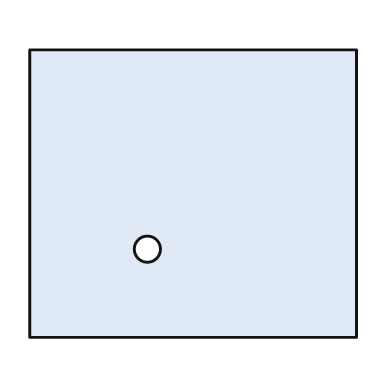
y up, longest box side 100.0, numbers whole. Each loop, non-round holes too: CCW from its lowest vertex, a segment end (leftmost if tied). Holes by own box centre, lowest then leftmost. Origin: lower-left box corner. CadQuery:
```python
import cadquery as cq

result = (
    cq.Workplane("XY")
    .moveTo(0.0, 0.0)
    .lineTo(100.0, 0.0)
    .lineTo(100.0, 88.0)
    .lineTo(0.0, 88.0)
    .close()
    .moveTo(36.0, 27.0)
    .circle(4.0)
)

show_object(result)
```